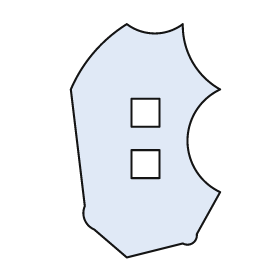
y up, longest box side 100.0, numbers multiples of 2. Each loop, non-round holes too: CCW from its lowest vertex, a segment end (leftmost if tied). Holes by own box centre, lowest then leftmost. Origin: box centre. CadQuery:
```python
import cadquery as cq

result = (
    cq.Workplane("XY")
    .moveTo(-8.0, -50.0)
    .lineTo(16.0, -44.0)
    .threePointArc((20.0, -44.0), (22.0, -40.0))
    .lineTo(32.0, -22.0)
    .threePointArc((18.0, 0.0), (32.0, 22.0))
    .threePointArc((20.0, 34.0), (16.0, 50.0))
    .threePointArc((4.0, 46.0), (-8.0, 50.0))
    .threePointArc((-22.0, 38.0), (-32.0, 22.0))
    .lineTo(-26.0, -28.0)
    .threePointArc((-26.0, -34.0), (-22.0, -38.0))
    .close()
    .moveTo(-6.0, -16.0)
    .lineTo(6.0, -16.0)
    .lineTo(6.0, -4.0)
    .lineTo(-6.0, -4.0)
    .close()
    .moveTo(-6.0, 6.0)
    .lineTo(6.0, 6.0)
    .lineTo(6.0, 18.0)
    .lineTo(-6.0, 18.0)
    .close()
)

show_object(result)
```